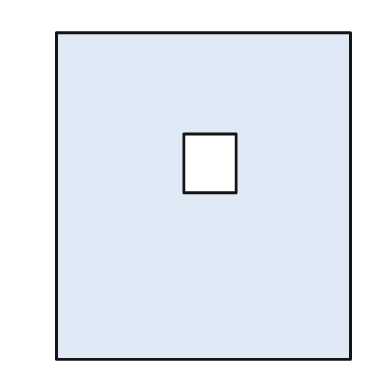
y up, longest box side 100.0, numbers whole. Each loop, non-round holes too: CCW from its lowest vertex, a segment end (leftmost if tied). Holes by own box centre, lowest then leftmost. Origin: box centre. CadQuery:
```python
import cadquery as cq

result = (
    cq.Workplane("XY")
    .moveTo(-45.0, -50.0)
    .lineTo(45.0, -50.0)
    .lineTo(45.0, 50.0)
    .lineTo(-45.0, 50.0)
    .close()
    .moveTo(-6.0, 1.0)
    .lineTo(10.0, 1.0)
    .lineTo(10.0, 19.0)
    .lineTo(-6.0, 19.0)
    .close()
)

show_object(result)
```